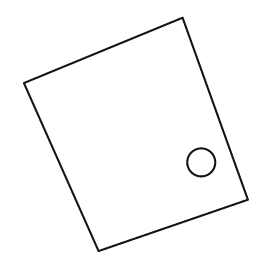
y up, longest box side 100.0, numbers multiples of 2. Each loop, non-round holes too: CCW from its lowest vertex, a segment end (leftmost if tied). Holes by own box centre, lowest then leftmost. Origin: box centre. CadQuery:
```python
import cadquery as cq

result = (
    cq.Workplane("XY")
    .moveTo(-16.0, -50.0)
    .lineTo(48.0, -28.0)
    .lineTo(20.0, 50.0)
    .lineTo(-48.0, 22.0)
    .close()
    .moveTo(28.0, -12.0)
    .circle(6.0)
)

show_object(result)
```